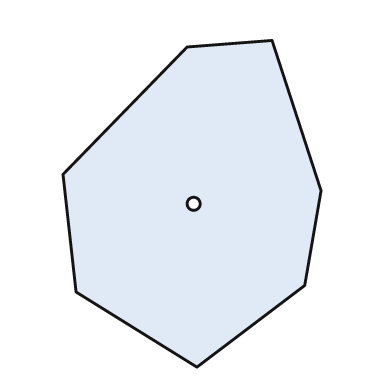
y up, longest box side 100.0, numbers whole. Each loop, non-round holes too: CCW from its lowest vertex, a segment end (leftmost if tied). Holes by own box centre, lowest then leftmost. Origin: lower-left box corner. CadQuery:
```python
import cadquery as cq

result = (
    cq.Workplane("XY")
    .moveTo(41.0, 0.0)
    .lineTo(74.0, 25.0)
    .lineTo(79.0, 54.0)
    .lineTo(64.0, 100.0)
    .lineTo(38.0, 98.0)
    .lineTo(0.0, 59.0)
    .lineTo(4.0, 23.0)
    .close()
    .moveTo(40.0, 50.0)
    .circle(2.0)
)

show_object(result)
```